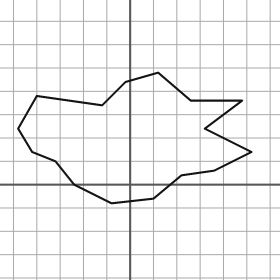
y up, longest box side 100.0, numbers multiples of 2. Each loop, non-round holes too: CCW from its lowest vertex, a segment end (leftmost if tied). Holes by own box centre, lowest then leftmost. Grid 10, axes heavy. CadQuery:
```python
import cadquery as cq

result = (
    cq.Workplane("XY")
    .moveTo(-8.0, -8.0)
    .lineTo(10.0, -6.0)
    .lineTo(22.0, 4.0)
    .lineTo(36.0, 6.0)
    .lineTo(52.0, 14.0)
    .lineTo(32.0, 24.0)
    .lineTo(48.0, 36.0)
    .lineTo(26.0, 36.0)
    .lineTo(12.0, 48.0)
    .lineTo(-2.0, 44.0)
    .lineTo(-12.0, 34.0)
    .lineTo(-40.0, 38.0)
    .lineTo(-48.0, 24.0)
    .lineTo(-42.0, 14.0)
    .lineTo(-32.0, 10.0)
    .lineTo(-24.0, 0.0)
    .close()
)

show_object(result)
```